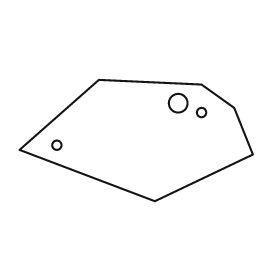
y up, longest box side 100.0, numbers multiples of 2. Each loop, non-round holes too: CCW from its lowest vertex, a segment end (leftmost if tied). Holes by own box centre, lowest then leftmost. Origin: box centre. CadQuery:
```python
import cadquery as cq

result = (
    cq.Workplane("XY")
    .moveTo(8.0, -26.0)
    .lineTo(50.0, -6.0)
    .lineTo(42.0, 14.0)
    .lineTo(28.0, 24.0)
    .lineTo(-16.0, 26.0)
    .lineTo(-50.0, -4.0)
    .close()
    .moveTo(-34.0, -2.0)
    .circle(2.0)
    .moveTo(28.0, 12.0)
    .circle(2.0)
    .moveTo(18.0, 16.0)
    .circle(4.0)
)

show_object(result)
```